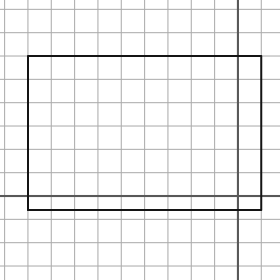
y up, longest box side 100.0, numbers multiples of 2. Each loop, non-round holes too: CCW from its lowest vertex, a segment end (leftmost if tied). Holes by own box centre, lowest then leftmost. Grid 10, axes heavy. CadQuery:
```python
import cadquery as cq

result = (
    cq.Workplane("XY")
    .moveTo(-90.0, -6.0)
    .lineTo(10.0, -6.0)
    .lineTo(10.0, 60.0)
    .lineTo(-90.0, 60.0)
    .close()
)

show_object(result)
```